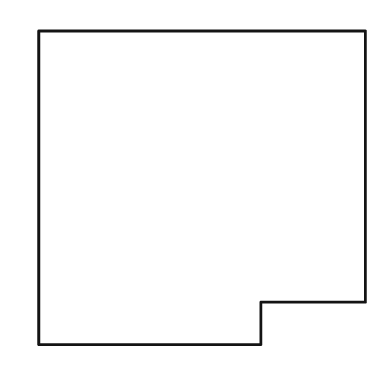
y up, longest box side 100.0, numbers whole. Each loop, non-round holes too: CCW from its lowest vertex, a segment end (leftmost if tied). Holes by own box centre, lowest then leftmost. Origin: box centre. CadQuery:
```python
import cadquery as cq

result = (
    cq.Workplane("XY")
    .moveTo(-50.0, -48.0)
    .lineTo(18.0, -48.0)
    .lineTo(18.0, -35.0)
    .lineTo(50.0, -35.0)
    .lineTo(50.0, 48.0)
    .lineTo(-50.0, 48.0)
    .close()
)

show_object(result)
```